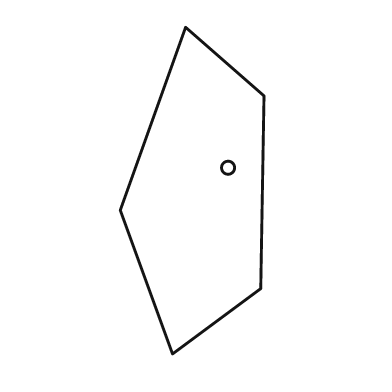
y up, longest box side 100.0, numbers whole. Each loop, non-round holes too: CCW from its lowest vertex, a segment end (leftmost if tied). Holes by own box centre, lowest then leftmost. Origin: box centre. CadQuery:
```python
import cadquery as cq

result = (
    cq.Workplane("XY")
    .moveTo(-6.0, -50.0)
    .lineTo(21.0, -30.0)
    .lineTo(22.0, 29.0)
    .lineTo(-2.0, 50.0)
    .lineTo(-22.0, -6.0)
    .close()
    .moveTo(11.0, 7.0)
    .circle(2.0)
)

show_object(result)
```